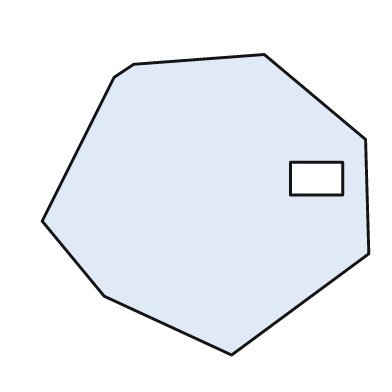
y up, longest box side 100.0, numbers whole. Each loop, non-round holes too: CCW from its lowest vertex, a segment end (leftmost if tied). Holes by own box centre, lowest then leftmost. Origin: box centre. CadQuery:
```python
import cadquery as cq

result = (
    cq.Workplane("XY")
    .moveTo(8.0, -46.0)
    .lineTo(50.0, -15.0)
    .lineTo(49.0, 20.0)
    .lineTo(18.0, 46.0)
    .lineTo(-22.0, 43.0)
    .lineTo(-28.0, 39.0)
    .lineTo(-50.0, -5.0)
    .lineTo(-31.0, -28.0)
    .close()
    .moveTo(26.0, 3.0)
    .lineTo(42.0, 3.0)
    .lineTo(42.0, 13.0)
    .lineTo(26.0, 13.0)
    .close()
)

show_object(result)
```